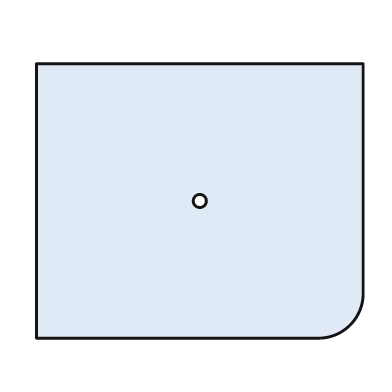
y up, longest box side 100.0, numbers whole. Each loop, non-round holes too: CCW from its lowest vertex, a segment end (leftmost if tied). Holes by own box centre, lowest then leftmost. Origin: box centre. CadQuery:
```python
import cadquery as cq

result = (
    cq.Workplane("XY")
    .moveTo(-50.0, -42.0)
    .lineTo(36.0, -42.0)
    .threePointArc((46.0, -38.0), (50.0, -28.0))
    .lineTo(50.0, 42.0)
    .lineTo(-50.0, 42.0)
    .close()
    .moveTo(0.0, 0.0)
    .circle(2.0)
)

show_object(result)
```